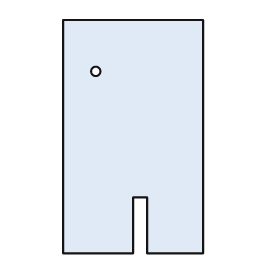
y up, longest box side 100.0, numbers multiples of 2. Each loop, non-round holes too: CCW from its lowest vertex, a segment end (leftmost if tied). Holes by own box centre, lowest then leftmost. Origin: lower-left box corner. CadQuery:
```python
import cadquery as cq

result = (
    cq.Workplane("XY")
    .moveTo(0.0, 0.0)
    .lineTo(30.0, 0.0)
    .lineTo(30.0, 24.0)
    .lineTo(36.0, 24.0)
    .lineTo(36.0, 0.0)
    .lineTo(60.0, 0.0)
    .lineTo(60.0, 100.0)
    .lineTo(0.0, 100.0)
    .close()
    .moveTo(14.0, 78.0)
    .circle(2.0)
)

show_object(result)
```